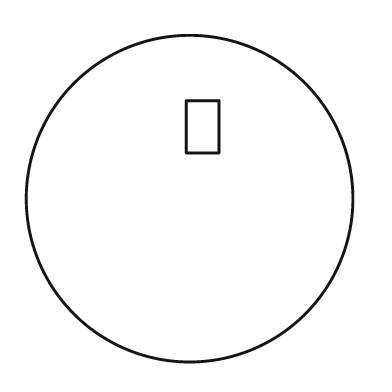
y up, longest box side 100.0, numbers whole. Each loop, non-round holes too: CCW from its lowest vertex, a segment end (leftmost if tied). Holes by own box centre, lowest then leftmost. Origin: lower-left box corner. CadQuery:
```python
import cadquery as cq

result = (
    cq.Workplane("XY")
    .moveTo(50.0, 50.0)
    .circle(50.0)
    .moveTo(49.0, 64.0)
    .lineTo(59.0, 64.0)
    .lineTo(59.0, 80.0)
    .lineTo(49.0, 80.0)
    .close()
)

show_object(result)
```